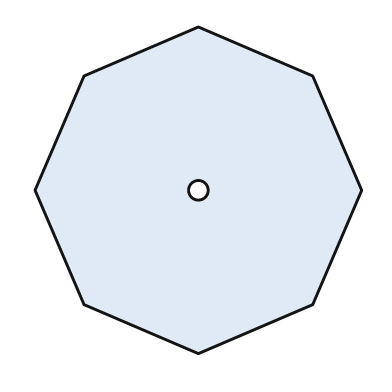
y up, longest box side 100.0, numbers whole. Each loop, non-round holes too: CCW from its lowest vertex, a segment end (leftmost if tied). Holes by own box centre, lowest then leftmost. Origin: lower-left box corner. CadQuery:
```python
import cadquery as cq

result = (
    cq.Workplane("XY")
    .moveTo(50.0, 0.0)
    .lineTo(85.0, 15.0)
    .lineTo(100.0, 50.0)
    .lineTo(85.0, 85.0)
    .lineTo(50.0, 100.0)
    .lineTo(15.0, 85.0)
    .lineTo(0.0, 50.0)
    .lineTo(15.0, 15.0)
    .close()
    .moveTo(50.0, 50.0)
    .circle(3.0)
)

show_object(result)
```